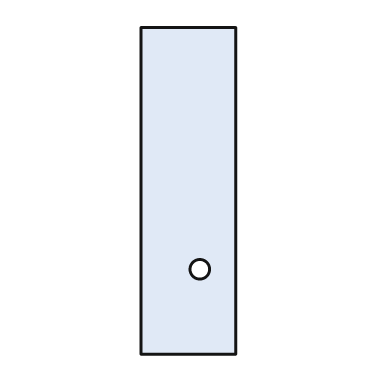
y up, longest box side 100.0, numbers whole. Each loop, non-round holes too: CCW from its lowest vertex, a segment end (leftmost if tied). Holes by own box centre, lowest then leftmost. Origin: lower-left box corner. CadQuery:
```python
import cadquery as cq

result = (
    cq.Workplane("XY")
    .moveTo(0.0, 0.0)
    .lineTo(29.0, 0.0)
    .lineTo(29.0, 100.0)
    .lineTo(0.0, 100.0)
    .close()
    .moveTo(18.0, 26.0)
    .circle(3.0)
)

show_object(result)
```